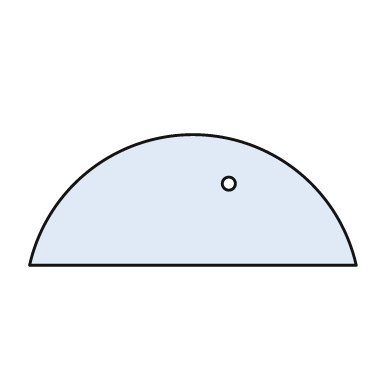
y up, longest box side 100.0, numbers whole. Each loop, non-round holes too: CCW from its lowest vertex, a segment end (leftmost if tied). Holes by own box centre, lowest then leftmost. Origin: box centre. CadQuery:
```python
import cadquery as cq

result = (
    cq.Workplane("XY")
    .moveTo(-50.0, -20.0)
    .lineTo(50.0, -20.0)
    .threePointArc((0.0, 20.0), (-50.0, -20.0))
    .close()
    .moveTo(11.0, 5.0)
    .circle(2.0)
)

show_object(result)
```